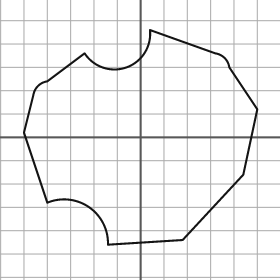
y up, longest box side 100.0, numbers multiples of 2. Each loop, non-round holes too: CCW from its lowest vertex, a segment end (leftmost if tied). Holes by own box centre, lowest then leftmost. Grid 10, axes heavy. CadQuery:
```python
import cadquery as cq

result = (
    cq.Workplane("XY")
    .moveTo(-14.0, -46.0)
    .lineTo(18.0, -44.0)
    .lineTo(44.0, -16.0)
    .lineTo(50.0, 12.0)
    .lineTo(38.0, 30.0)
    .threePointArc((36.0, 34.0), (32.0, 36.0))
    .lineTo(4.0, 46.0)
    .threePointArc((-6.0, 30.0), (-24.0, 36.0))
    .lineTo(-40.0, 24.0)
    .threePointArc((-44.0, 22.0), (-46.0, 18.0))
    .lineTo(-50.0, 2.0)
    .lineTo(-40.0, -28.0)
    .threePointArc((-22.0, -30.0), (-14.0, -46.0))
    .close()
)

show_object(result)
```